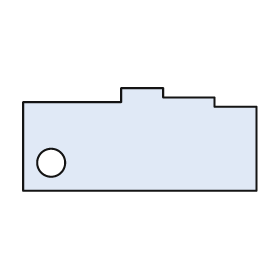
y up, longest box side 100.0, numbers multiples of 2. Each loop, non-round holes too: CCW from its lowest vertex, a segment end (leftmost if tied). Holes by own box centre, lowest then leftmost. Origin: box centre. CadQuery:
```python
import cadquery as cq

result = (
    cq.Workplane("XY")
    .moveTo(-50.0, -22.0)
    .lineTo(50.0, -22.0)
    .lineTo(50.0, 14.0)
    .lineTo(32.0, 14.0)
    .lineTo(32.0, 18.0)
    .lineTo(10.0, 18.0)
    .lineTo(10.0, 22.0)
    .lineTo(-8.0, 22.0)
    .lineTo(-8.0, 16.0)
    .lineTo(-50.0, 16.0)
    .close()
    .moveTo(-38.0, -10.0)
    .circle(6.0)
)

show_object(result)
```